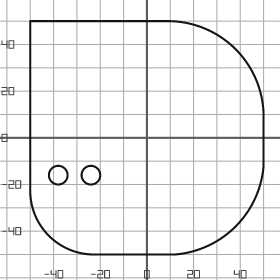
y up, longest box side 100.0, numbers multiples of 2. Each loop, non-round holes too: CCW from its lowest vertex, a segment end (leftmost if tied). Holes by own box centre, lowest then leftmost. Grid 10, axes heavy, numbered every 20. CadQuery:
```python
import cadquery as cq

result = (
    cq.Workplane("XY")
    .moveTo(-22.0, -50.0)
    .lineTo(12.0, -50.0)
    .threePointArc((38.0, -38.0), (50.0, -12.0))
    .lineTo(50.0, 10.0)
    .threePointArc((38.0, 38.0), (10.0, 50.0))
    .lineTo(-50.0, 50.0)
    .lineTo(-50.0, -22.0)
    .threePointArc((-42.0, -42.0), (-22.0, -50.0))
    .close()
    .moveTo(-38.0, -16.0)
    .circle(4.0)
    .moveTo(-24.0, -16.0)
    .circle(4.0)
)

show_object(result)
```